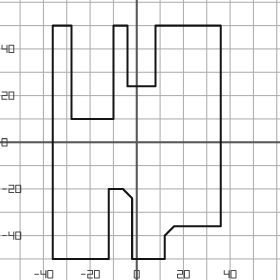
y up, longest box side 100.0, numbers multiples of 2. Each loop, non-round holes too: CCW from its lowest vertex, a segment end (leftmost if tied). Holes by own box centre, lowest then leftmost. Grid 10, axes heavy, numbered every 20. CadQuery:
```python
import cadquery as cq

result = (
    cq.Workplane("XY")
    .moveTo(-36.0, -50.0)
    .lineTo(-12.0, -50.0)
    .lineTo(-12.0, -20.0)
    .lineTo(-6.0, -20.0)
    .lineTo(-2.0, -24.0)
    .lineTo(-2.0, -50.0)
    .lineTo(12.0, -50.0)
    .lineTo(12.0, -40.0)
    .lineTo(16.0, -36.0)
    .lineTo(36.0, -36.0)
    .lineTo(36.0, 50.0)
    .lineTo(8.0, 50.0)
    .lineTo(8.0, 24.0)
    .lineTo(-4.0, 24.0)
    .lineTo(-4.0, 50.0)
    .lineTo(-10.0, 50.0)
    .lineTo(-10.0, 10.0)
    .lineTo(-28.0, 10.0)
    .lineTo(-28.0, 50.0)
    .lineTo(-36.0, 50.0)
    .close()
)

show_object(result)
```